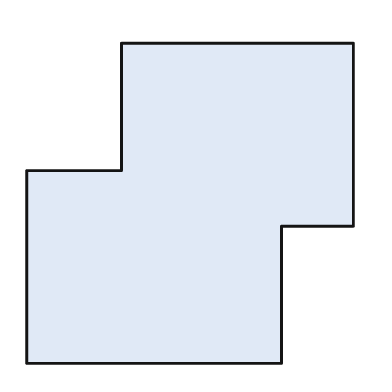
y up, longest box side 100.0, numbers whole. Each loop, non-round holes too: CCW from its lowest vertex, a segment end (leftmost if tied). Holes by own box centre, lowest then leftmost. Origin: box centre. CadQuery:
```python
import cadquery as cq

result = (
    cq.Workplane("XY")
    .moveTo(-50.0, -49.0)
    .lineTo(28.0, -49.0)
    .lineTo(28.0, -7.0)
    .lineTo(50.0, -7.0)
    .lineTo(50.0, 49.0)
    .lineTo(-21.0, 49.0)
    .lineTo(-21.0, 10.0)
    .lineTo(-50.0, 10.0)
    .close()
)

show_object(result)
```